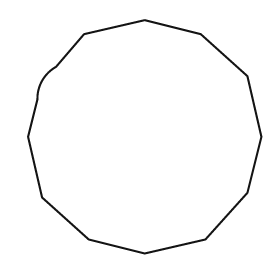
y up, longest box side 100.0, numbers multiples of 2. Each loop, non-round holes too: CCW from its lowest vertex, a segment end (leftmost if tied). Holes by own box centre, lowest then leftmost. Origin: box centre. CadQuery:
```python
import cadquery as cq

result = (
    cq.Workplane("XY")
    .moveTo(0.0, -50.0)
    .lineTo(26.0, -44.0)
    .lineTo(44.0, -24.0)
    .lineTo(50.0, 0.0)
    .lineTo(44.0, 26.0)
    .lineTo(24.0, 44.0)
    .lineTo(0.0, 50.0)
    .lineTo(-26.0, 44.0)
    .lineTo(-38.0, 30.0)
    .threePointArc((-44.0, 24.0), (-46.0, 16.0))
    .lineTo(-50.0, 0.0)
    .lineTo(-44.0, -26.0)
    .lineTo(-24.0, -44.0)
    .close()
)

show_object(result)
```